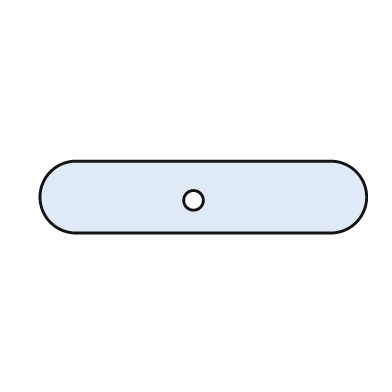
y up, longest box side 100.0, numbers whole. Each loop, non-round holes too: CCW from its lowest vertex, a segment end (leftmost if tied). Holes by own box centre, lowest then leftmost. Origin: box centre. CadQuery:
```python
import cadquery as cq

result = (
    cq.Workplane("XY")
    .moveTo(-39.0, -11.0)
    .lineTo(39.0, -11.0)
    .threePointArc((50.0, 0.0), (39.0, 11.0))
    .lineTo(-39.0, 11.0)
    .threePointArc((-50.0, 0.0), (-39.0, -11.0))
    .close()
    .moveTo(-3.0, -1.0)
    .circle(3.0)
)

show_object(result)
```